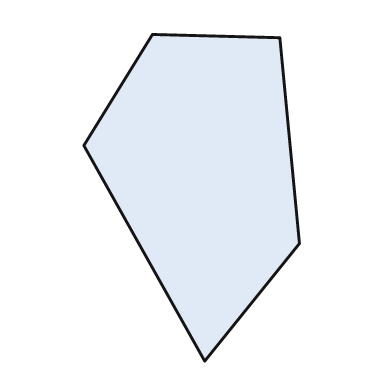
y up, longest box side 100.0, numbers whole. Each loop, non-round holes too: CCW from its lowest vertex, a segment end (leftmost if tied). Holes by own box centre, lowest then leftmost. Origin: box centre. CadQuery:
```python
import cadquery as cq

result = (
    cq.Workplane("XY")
    .moveTo(4.0, -50.0)
    .lineTo(33.0, -14.0)
    .lineTo(27.0, 49.0)
    .lineTo(-12.0, 50.0)
    .lineTo(-33.0, 16.0)
    .close()
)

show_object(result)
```